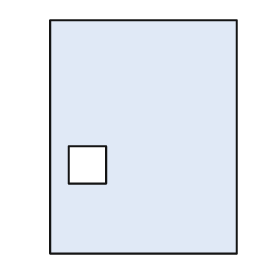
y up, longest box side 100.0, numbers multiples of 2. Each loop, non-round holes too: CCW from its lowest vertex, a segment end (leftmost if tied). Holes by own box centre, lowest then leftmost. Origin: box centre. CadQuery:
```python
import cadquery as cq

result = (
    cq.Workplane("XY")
    .moveTo(-40.0, -50.0)
    .lineTo(40.0, -50.0)
    .lineTo(40.0, 50.0)
    .lineTo(-40.0, 50.0)
    .close()
    .moveTo(-32.0, -20.0)
    .lineTo(-16.0, -20.0)
    .lineTo(-16.0, -4.0)
    .lineTo(-32.0, -4.0)
    .close()
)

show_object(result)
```